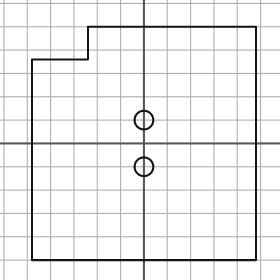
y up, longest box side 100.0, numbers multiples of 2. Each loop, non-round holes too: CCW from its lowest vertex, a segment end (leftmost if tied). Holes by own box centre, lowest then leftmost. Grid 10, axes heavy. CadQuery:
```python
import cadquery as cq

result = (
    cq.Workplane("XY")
    .moveTo(-48.0, -50.0)
    .lineTo(48.0, -50.0)
    .lineTo(48.0, 50.0)
    .lineTo(-24.0, 50.0)
    .lineTo(-24.0, 36.0)
    .lineTo(-48.0, 36.0)
    .close()
    .moveTo(0.0, -10.0)
    .circle(4.0)
    .moveTo(0.0, 10.0)
    .circle(4.0)
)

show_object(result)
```